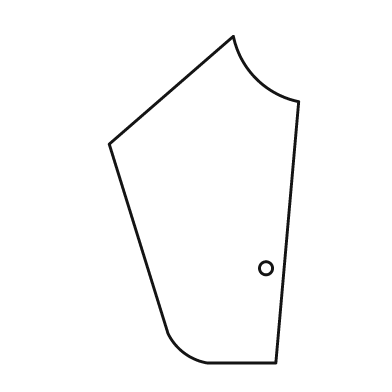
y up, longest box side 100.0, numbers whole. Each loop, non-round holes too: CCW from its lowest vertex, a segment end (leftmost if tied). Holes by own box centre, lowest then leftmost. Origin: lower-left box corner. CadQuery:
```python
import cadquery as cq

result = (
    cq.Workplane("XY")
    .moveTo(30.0, 0.0)
    .lineTo(51.0, 0.0)
    .lineTo(58.0, 80.0)
    .threePointArc((45.0, 87.0), (38.0, 100.0))
    .lineTo(0.0, 67.0)
    .lineTo(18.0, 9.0)
    .threePointArc((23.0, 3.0), (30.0, 0.0))
    .close()
    .moveTo(48.0, 29.0)
    .circle(2.0)
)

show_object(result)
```